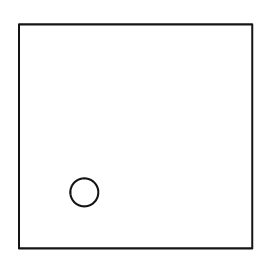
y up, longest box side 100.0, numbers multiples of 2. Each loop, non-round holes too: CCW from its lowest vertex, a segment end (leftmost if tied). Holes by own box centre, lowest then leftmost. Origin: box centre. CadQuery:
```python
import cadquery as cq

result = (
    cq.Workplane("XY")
    .moveTo(-50.0, -48.0)
    .lineTo(50.0, -48.0)
    .lineTo(50.0, 48.0)
    .lineTo(-50.0, 48.0)
    .close()
    .moveTo(-22.0, -24.0)
    .circle(6.0)
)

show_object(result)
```